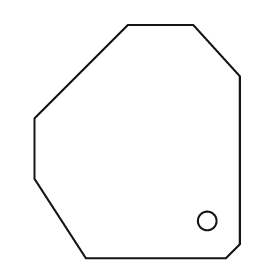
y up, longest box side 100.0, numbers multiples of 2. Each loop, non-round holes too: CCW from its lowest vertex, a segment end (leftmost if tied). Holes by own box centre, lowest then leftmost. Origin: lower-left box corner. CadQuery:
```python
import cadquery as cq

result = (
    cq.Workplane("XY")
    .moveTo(22.0, 0.0)
    .lineTo(82.0, 0.0)
    .lineTo(88.0, 6.0)
    .lineTo(88.0, 78.0)
    .lineTo(68.0, 100.0)
    .lineTo(40.0, 100.0)
    .lineTo(0.0, 60.0)
    .lineTo(0.0, 34.0)
    .close()
    .moveTo(74.0, 16.0)
    .circle(4.0)
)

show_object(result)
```